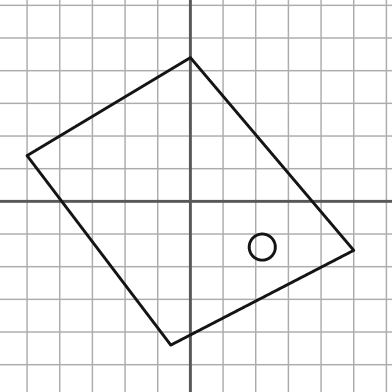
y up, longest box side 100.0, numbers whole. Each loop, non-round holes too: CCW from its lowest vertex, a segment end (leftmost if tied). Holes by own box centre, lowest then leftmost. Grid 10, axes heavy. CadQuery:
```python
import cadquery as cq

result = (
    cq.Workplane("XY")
    .moveTo(-6.0, -44.0)
    .lineTo(50.0, -15.0)
    .lineTo(0.0, 44.0)
    .lineTo(-50.0, 14.0)
    .close()
    .moveTo(22.0, -14.0)
    .circle(4.0)
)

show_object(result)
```